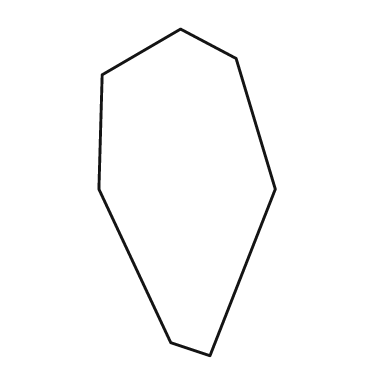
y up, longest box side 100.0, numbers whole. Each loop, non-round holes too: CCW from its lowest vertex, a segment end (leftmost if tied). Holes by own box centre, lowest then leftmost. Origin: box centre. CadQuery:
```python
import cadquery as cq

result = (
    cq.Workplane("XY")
    .moveTo(7.0, -50.0)
    .lineTo(27.0, 1.0)
    .lineTo(15.0, 41.0)
    .lineTo(-2.0, 50.0)
    .lineTo(-26.0, 36.0)
    .lineTo(-27.0, 1.0)
    .lineTo(-5.0, -46.0)
    .close()
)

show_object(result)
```